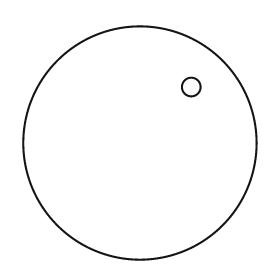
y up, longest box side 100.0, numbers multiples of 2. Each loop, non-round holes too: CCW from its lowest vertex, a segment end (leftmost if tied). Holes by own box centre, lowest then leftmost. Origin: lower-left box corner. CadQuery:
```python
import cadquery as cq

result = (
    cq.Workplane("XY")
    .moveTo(50.0, 50.0)
    .circle(50.0)
    .moveTo(72.0, 74.0)
    .circle(4.0)
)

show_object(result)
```